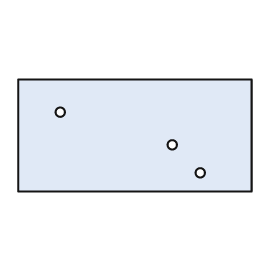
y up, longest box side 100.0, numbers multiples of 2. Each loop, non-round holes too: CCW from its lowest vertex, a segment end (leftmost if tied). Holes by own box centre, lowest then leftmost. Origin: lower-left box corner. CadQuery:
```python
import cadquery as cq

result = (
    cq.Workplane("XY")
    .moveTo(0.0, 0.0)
    .lineTo(100.0, 0.0)
    .lineTo(100.0, 48.0)
    .lineTo(0.0, 48.0)
    .close()
    .moveTo(78.0, 8.0)
    .circle(2.0)
    .moveTo(66.0, 20.0)
    .circle(2.0)
    .moveTo(18.0, 34.0)
    .circle(2.0)
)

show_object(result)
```